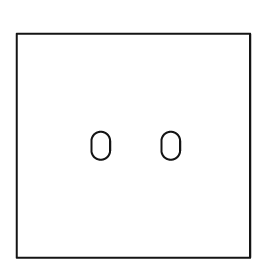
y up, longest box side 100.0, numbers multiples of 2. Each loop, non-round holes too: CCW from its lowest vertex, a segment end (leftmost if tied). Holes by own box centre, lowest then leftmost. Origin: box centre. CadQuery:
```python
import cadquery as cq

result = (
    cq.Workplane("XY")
    .moveTo(-50.0, -48.0)
    .lineTo(50.0, -48.0)
    .lineTo(50.0, 48.0)
    .lineTo(-50.0, 48.0)
    .close()
    .moveTo(-18.0, -2.0)
    .threePointArc((-14.0, -6.0), (-10.0, -2.0))
    .lineTo(-10.0, 2.0)
    .threePointArc((-14.0, 6.0), (-18.0, 2.0))
    .close()
    .moveTo(12.0, -2.0)
    .threePointArc((16.0, -6.0), (20.0, -2.0))
    .lineTo(20.0, 2.0)
    .threePointArc((16.0, 6.0), (12.0, 2.0))
    .close()
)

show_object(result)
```